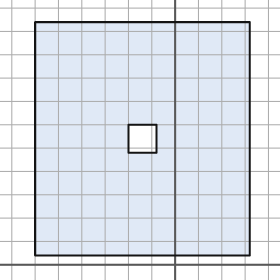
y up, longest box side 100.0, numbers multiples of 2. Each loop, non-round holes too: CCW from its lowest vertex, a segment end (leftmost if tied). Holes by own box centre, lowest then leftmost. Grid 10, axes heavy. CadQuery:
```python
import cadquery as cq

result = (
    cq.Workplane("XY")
    .moveTo(-60.0, 4.0)
    .lineTo(32.0, 4.0)
    .lineTo(32.0, 104.0)
    .lineTo(-60.0, 104.0)
    .close()
    .moveTo(-20.0, 48.0)
    .lineTo(-8.0, 48.0)
    .lineTo(-8.0, 60.0)
    .lineTo(-20.0, 60.0)
    .close()
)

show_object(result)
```